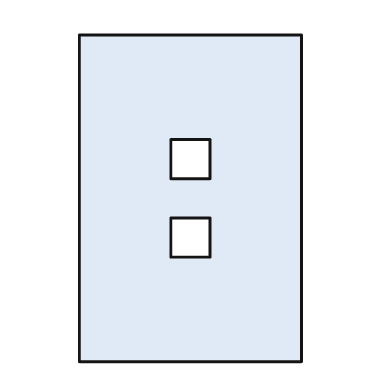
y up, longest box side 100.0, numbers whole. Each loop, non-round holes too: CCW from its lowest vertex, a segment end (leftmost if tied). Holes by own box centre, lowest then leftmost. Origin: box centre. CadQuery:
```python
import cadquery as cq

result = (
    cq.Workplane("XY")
    .moveTo(-34.0, -50.0)
    .lineTo(34.0, -50.0)
    .lineTo(34.0, 50.0)
    .lineTo(-34.0, 50.0)
    .close()
    .moveTo(-6.0, -18.0)
    .lineTo(6.0, -18.0)
    .lineTo(6.0, -6.0)
    .lineTo(-6.0, -6.0)
    .close()
    .moveTo(-6.0, 6.0)
    .lineTo(6.0, 6.0)
    .lineTo(6.0, 18.0)
    .lineTo(-6.0, 18.0)
    .close()
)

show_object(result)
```